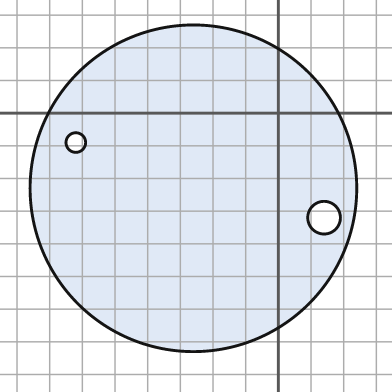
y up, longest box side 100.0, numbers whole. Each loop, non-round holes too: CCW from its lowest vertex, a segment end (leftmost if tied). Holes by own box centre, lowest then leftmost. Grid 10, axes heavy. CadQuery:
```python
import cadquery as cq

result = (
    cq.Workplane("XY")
    .moveTo(-26.0, -23.0)
    .circle(50.0)
    .moveTo(14.0, -32.0)
    .circle(5.0)
    .moveTo(-62.0, -9.0)
    .circle(3.0)
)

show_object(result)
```